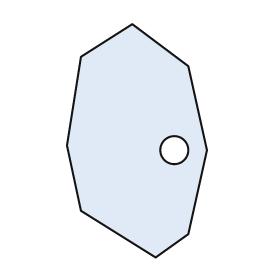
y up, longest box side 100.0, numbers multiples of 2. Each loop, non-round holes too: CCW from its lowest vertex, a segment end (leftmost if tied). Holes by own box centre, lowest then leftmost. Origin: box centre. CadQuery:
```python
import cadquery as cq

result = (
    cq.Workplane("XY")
    .moveTo(8.0, -50.0)
    .lineTo(22.0, -40.0)
    .lineTo(30.0, -4.0)
    .lineTo(22.0, 32.0)
    .lineTo(-2.0, 50.0)
    .lineTo(-24.0, 36.0)
    .lineTo(-30.0, -2.0)
    .lineTo(-24.0, -30.0)
    .close()
    .moveTo(16.0, -4.0)
    .circle(6.0)
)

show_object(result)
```